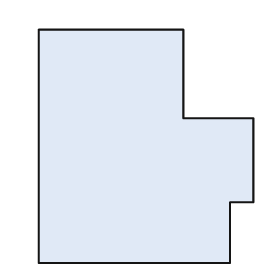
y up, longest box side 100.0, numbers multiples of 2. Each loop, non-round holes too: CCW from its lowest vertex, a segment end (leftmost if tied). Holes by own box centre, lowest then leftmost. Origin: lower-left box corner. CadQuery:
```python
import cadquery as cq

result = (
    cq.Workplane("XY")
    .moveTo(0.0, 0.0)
    .lineTo(82.0, 0.0)
    .lineTo(82.0, 26.0)
    .lineTo(92.0, 26.0)
    .lineTo(92.0, 62.0)
    .lineTo(62.0, 62.0)
    .lineTo(62.0, 100.0)
    .lineTo(0.0, 100.0)
    .close()
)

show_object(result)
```